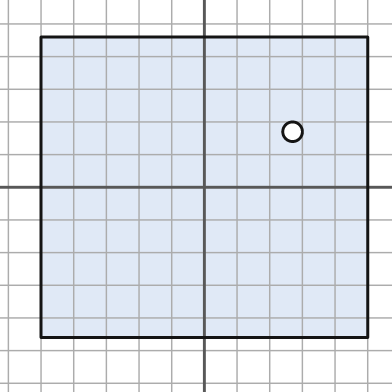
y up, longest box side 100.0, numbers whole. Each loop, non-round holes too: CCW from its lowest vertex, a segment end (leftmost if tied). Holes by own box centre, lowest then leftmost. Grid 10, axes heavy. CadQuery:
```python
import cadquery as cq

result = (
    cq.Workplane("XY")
    .moveTo(-50.0, -46.0)
    .lineTo(50.0, -46.0)
    .lineTo(50.0, 46.0)
    .lineTo(-50.0, 46.0)
    .close()
    .moveTo(27.0, 17.0)
    .circle(3.0)
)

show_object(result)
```